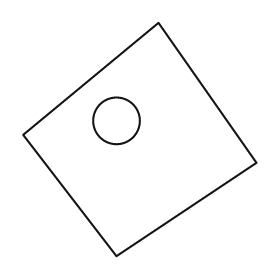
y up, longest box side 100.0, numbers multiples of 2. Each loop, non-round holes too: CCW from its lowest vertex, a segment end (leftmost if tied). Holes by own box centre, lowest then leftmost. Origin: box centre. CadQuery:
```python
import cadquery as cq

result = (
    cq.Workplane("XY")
    .moveTo(-10.0, -50.0)
    .lineTo(50.0, -10.0)
    .lineTo(8.0, 50.0)
    .lineTo(-50.0, 2.0)
    .close()
    .moveTo(-10.0, 8.0)
    .circle(10.0)
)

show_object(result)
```